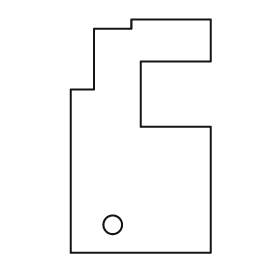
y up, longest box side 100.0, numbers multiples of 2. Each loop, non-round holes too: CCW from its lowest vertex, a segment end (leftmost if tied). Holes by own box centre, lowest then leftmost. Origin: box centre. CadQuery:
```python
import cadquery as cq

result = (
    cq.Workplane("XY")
    .moveTo(-30.0, -50.0)
    .lineTo(30.0, -50.0)
    .lineTo(30.0, 4.0)
    .lineTo(0.0, 4.0)
    .lineTo(0.0, 32.0)
    .lineTo(30.0, 32.0)
    .lineTo(30.0, 50.0)
    .lineTo(-4.0, 50.0)
    .lineTo(-4.0, 46.0)
    .lineTo(-20.0, 46.0)
    .lineTo(-20.0, 20.0)
    .lineTo(-30.0, 20.0)
    .close()
    .moveTo(-12.0, -38.0)
    .circle(4.0)
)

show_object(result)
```